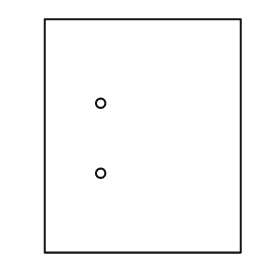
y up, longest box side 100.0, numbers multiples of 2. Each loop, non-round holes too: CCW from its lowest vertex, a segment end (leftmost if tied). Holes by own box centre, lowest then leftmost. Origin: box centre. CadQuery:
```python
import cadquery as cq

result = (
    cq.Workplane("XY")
    .moveTo(-42.0, -50.0)
    .lineTo(42.0, -50.0)
    .lineTo(42.0, 50.0)
    .lineTo(-42.0, 50.0)
    .close()
    .moveTo(-18.0, -16.0)
    .circle(2.0)
    .moveTo(-18.0, 14.0)
    .circle(2.0)
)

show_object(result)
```